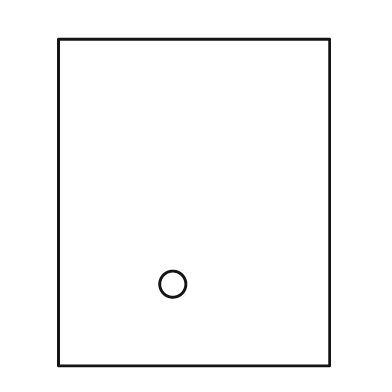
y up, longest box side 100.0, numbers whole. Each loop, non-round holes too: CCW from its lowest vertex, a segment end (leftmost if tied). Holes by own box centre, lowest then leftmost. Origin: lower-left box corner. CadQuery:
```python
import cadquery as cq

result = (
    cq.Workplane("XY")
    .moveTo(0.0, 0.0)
    .lineTo(83.0, 0.0)
    .lineTo(83.0, 100.0)
    .lineTo(0.0, 100.0)
    .close()
    .moveTo(35.0, 25.0)
    .circle(4.0)
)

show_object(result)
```